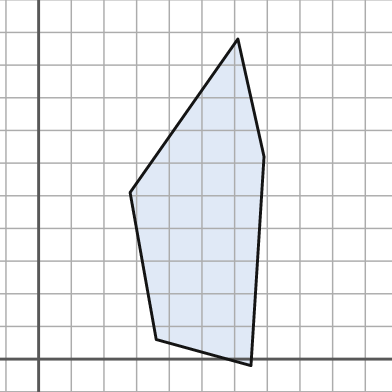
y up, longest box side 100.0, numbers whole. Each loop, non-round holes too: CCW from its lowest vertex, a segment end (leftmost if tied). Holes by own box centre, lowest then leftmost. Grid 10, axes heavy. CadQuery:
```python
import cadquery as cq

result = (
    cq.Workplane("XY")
    .moveTo(65.0, -2.0)
    .lineTo(69.0, 62.0)
    .lineTo(61.0, 98.0)
    .lineTo(28.0, 51.0)
    .lineTo(36.0, 6.0)
    .close()
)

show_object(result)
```